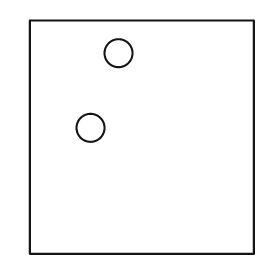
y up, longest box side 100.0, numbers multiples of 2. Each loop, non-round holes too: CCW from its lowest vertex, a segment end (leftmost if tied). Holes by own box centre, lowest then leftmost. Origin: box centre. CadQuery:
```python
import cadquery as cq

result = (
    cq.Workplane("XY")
    .moveTo(-48.0, -50.0)
    .lineTo(48.0, -50.0)
    .lineTo(48.0, 50.0)
    .lineTo(-48.0, 50.0)
    .close()
    .moveTo(-22.0, 4.0)
    .circle(6.0)
    .moveTo(-10.0, 36.0)
    .circle(6.0)
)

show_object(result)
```